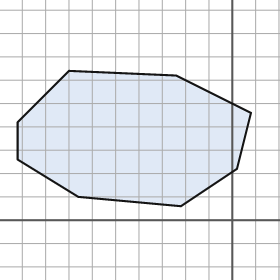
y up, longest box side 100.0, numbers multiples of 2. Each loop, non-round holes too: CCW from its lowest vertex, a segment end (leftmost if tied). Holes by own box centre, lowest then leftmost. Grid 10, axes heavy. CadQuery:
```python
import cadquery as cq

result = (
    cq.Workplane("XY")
    .moveTo(-22.0, 6.0)
    .lineTo(2.0, 22.0)
    .lineTo(8.0, 46.0)
    .lineTo(-24.0, 62.0)
    .lineTo(-70.0, 64.0)
    .lineTo(-92.0, 42.0)
    .lineTo(-92.0, 26.0)
    .lineTo(-66.0, 10.0)
    .close()
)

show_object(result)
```